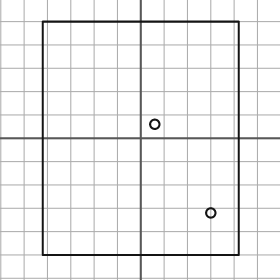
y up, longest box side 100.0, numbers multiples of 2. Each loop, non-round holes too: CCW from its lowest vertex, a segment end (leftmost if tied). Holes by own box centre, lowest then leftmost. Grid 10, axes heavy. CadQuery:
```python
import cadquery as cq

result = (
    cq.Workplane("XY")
    .moveTo(-42.0, -50.0)
    .lineTo(42.0, -50.0)
    .lineTo(42.0, 50.0)
    .lineTo(-42.0, 50.0)
    .close()
    .moveTo(30.0, -32.0)
    .circle(2.0)
    .moveTo(6.0, 6.0)
    .circle(2.0)
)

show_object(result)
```